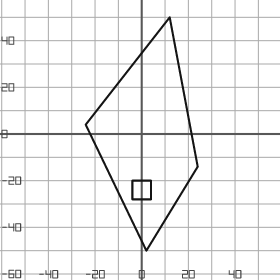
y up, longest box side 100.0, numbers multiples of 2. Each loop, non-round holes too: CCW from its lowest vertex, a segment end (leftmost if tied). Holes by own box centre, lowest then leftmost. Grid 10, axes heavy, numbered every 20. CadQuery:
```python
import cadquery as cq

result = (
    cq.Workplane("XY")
    .moveTo(2.0, -50.0)
    .lineTo(24.0, -14.0)
    .lineTo(12.0, 50.0)
    .lineTo(-24.0, 4.0)
    .close()
    .moveTo(-4.0, -28.0)
    .lineTo(4.0, -28.0)
    .lineTo(4.0, -20.0)
    .lineTo(-4.0, -20.0)
    .close()
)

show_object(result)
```